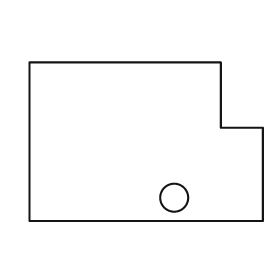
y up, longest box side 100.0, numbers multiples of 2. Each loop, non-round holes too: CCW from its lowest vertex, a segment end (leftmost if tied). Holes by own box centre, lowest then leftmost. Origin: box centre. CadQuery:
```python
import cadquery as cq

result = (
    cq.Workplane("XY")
    .moveTo(-50.0, -34.0)
    .lineTo(50.0, -34.0)
    .lineTo(50.0, 6.0)
    .lineTo(32.0, 6.0)
    .lineTo(32.0, 34.0)
    .lineTo(-50.0, 34.0)
    .close()
    .moveTo(12.0, -24.0)
    .circle(6.0)
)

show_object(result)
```